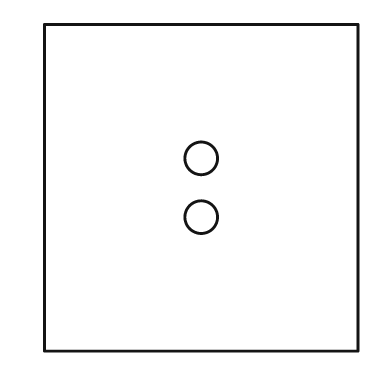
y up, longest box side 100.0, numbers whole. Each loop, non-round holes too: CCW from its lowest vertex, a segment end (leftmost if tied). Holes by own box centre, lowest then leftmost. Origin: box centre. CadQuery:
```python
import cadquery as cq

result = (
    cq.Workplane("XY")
    .moveTo(-48.0, -50.0)
    .lineTo(48.0, -50.0)
    .lineTo(48.0, 50.0)
    .lineTo(-48.0, 50.0)
    .close()
    .moveTo(0.0, -9.0)
    .circle(5.0)
    .moveTo(0.0, 9.0)
    .circle(5.0)
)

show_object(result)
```